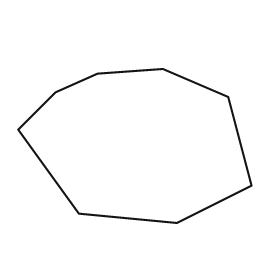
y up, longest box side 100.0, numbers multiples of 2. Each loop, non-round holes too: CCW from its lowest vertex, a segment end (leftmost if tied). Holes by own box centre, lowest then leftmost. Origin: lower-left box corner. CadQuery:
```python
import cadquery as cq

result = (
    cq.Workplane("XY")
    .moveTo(68.0, 0.0)
    .lineTo(100.0, 16.0)
    .lineTo(90.0, 54.0)
    .lineTo(62.0, 66.0)
    .lineTo(34.0, 64.0)
    .lineTo(16.0, 56.0)
    .lineTo(0.0, 40.0)
    .lineTo(26.0, 4.0)
    .close()
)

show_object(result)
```